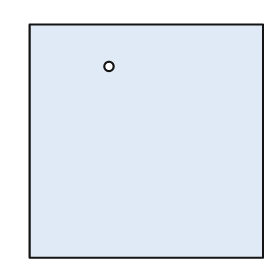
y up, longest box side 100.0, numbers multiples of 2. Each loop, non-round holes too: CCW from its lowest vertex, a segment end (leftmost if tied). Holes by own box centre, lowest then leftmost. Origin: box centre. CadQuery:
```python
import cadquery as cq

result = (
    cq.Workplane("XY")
    .moveTo(-50.0, -50.0)
    .lineTo(50.0, -50.0)
    .lineTo(50.0, 50.0)
    .lineTo(-50.0, 50.0)
    .close()
    .moveTo(-16.0, 32.0)
    .circle(2.0)
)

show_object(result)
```